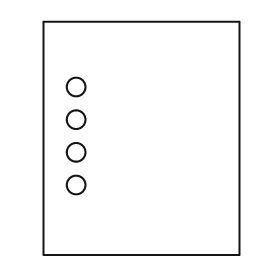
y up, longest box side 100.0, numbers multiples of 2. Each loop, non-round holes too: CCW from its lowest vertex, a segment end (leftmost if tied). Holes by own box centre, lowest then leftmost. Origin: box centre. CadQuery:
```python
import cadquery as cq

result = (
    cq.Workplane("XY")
    .moveTo(-42.0, -50.0)
    .lineTo(42.0, -50.0)
    .lineTo(42.0, 50.0)
    .lineTo(-42.0, 50.0)
    .close()
    .moveTo(-28.0, -20.0)
    .circle(4.0)
    .moveTo(-28.0, -6.0)
    .circle(4.0)
    .moveTo(-28.0, 8.0)
    .circle(4.0)
    .moveTo(-28.0, 22.0)
    .circle(4.0)
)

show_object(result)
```